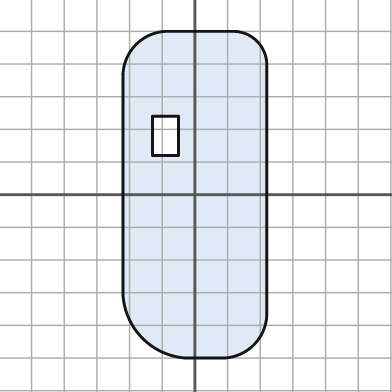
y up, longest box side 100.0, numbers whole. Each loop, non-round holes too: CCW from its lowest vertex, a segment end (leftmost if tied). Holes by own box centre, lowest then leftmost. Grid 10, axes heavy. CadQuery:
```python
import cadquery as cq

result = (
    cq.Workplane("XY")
    .moveTo(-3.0, -50.0)
    .lineTo(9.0, -50.0)
    .threePointArc((18.0, -46.0), (22.0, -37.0))
    .lineTo(22.0, 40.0)
    .threePointArc((19.0, 47.0), (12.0, 50.0))
    .lineTo(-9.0, 50.0)
    .threePointArc((-18.0, 46.0), (-22.0, 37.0))
    .lineTo(-22.0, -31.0)
    .threePointArc((-16.0, -44.0), (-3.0, -50.0))
    .close()
    .moveTo(-13.0, 12.0)
    .lineTo(-5.0, 12.0)
    .lineTo(-5.0, 24.0)
    .lineTo(-13.0, 24.0)
    .close()
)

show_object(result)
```